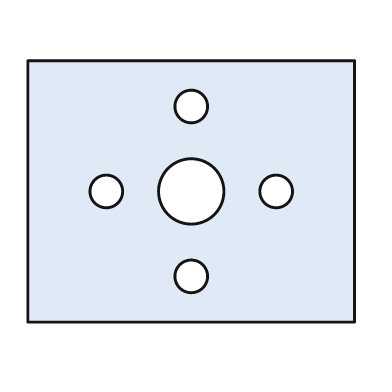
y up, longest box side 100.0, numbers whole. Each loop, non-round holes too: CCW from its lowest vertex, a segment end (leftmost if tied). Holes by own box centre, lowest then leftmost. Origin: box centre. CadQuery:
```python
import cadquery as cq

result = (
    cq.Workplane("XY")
    .moveTo(-50.0, -40.0)
    .lineTo(50.0, -40.0)
    .lineTo(50.0, 40.0)
    .lineTo(-50.0, 40.0)
    .close()
    .moveTo(0.0, -26.0)
    .circle(5.0)
    .moveTo(-26.0, 0.0)
    .circle(5.0)
    .moveTo(0.0, 0.0)
    .circle(10.0)
    .moveTo(26.0, 0.0)
    .circle(5.0)
    .moveTo(0.0, 26.0)
    .circle(5.0)
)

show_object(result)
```